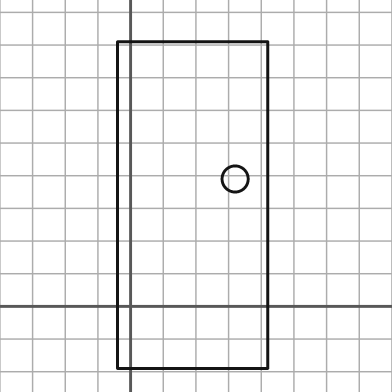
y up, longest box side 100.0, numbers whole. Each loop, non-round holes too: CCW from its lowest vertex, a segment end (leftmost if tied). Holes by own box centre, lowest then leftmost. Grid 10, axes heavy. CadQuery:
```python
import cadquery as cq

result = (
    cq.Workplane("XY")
    .moveTo(-4.0, -19.0)
    .lineTo(42.0, -19.0)
    .lineTo(42.0, 81.0)
    .lineTo(-4.0, 81.0)
    .close()
    .moveTo(32.0, 39.0)
    .circle(4.0)
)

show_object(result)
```